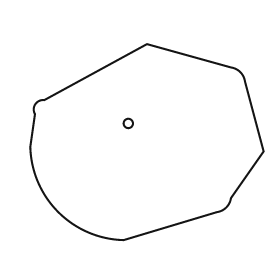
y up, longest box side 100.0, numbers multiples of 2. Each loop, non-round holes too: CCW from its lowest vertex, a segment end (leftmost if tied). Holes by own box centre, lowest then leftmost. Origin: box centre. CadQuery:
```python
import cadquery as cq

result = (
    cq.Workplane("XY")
    .moveTo(-10.0, -42.0)
    .lineTo(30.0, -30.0)
    .threePointArc((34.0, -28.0), (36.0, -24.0))
    .lineTo(50.0, -4.0)
    .lineTo(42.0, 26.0)
    .threePointArc((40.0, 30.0), (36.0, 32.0))
    .lineTo(0.0, 42.0)
    .lineTo(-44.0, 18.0)
    .threePointArc((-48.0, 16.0), (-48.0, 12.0))
    .lineTo(-50.0, -2.0)
    .threePointArc((-38.0, -30.0), (-10.0, -42.0))
    .close()
    .moveTo(-8.0, 8.0)
    .circle(2.0)
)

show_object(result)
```